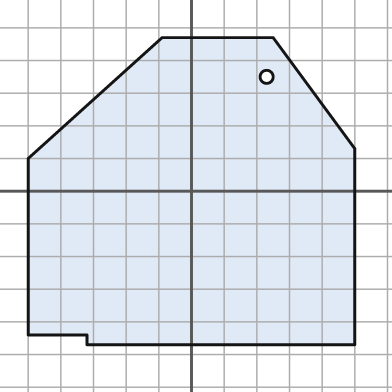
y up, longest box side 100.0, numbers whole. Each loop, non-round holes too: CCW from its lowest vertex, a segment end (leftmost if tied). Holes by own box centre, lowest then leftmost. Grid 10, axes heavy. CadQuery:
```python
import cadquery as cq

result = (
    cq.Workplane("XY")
    .moveTo(-32.0, -47.0)
    .lineTo(50.0, -47.0)
    .lineTo(50.0, 13.0)
    .lineTo(25.0, 47.0)
    .lineTo(-9.0, 47.0)
    .lineTo(-50.0, 10.0)
    .lineTo(-50.0, -44.0)
    .lineTo(-32.0, -44.0)
    .close()
    .moveTo(23.0, 35.0)
    .circle(2.0)
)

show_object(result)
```